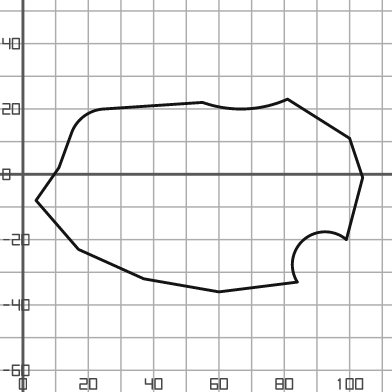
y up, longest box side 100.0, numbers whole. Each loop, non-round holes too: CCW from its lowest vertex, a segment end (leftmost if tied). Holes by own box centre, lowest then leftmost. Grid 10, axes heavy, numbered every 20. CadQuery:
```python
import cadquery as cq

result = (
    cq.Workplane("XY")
    .moveTo(60.0, -36.0)
    .lineTo(84.0, -33.0)
    .threePointArc((86.0, -20.0), (99.0, -20.0))
    .lineTo(104.0, -1.0)
    .lineTo(100.0, 11.0)
    .lineTo(81.0, 23.0)
    .threePointArc((68.0, 20.0), (55.0, 22.0))
    .lineTo(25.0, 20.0)
    .threePointArc((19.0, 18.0), (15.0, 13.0))
    .lineTo(11.0, 2.0)
    .lineTo(4.0, -8.0)
    .lineTo(17.0, -23.0)
    .lineTo(37.0, -32.0)
    .close()
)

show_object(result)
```